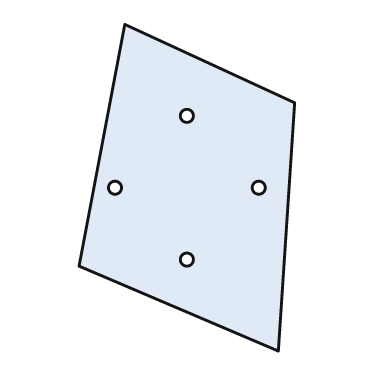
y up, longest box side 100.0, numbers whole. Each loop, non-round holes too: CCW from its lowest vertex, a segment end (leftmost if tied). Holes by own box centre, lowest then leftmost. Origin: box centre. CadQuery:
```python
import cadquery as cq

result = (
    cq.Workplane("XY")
    .moveTo(28.0, -50.0)
    .lineTo(33.0, 26.0)
    .lineTo(-19.0, 50.0)
    .lineTo(-33.0, -24.0)
    .close()
    .moveTo(0.0, -22.0)
    .circle(2.0)
    .moveTo(-22.0, 0.0)
    .circle(2.0)
    .moveTo(22.0, 0.0)
    .circle(2.0)
    .moveTo(0.0, 22.0)
    .circle(2.0)
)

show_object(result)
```